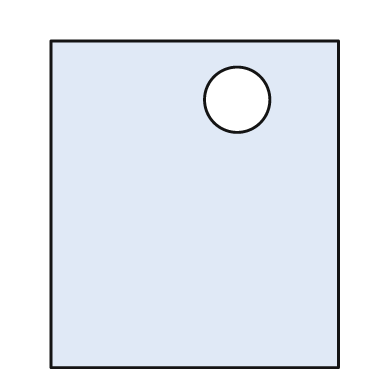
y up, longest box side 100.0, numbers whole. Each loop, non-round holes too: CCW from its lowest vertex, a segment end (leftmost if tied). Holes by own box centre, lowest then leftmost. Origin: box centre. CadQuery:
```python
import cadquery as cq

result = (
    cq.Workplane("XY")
    .moveTo(-44.0, -50.0)
    .lineTo(44.0, -50.0)
    .lineTo(44.0, 50.0)
    .lineTo(-44.0, 50.0)
    .close()
    .moveTo(13.0, 32.0)
    .circle(10.0)
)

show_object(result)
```